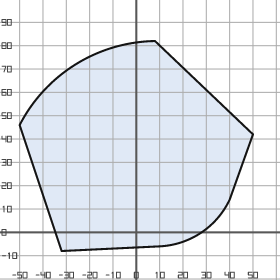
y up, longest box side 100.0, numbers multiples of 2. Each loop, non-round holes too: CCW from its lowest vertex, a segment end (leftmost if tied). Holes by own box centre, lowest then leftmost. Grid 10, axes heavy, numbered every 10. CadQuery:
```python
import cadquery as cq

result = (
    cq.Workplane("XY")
    .moveTo(-32.0, -8.0)
    .lineTo(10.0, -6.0)
    .threePointArc((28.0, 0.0), (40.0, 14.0))
    .lineTo(50.0, 42.0)
    .lineTo(8.0, 82.0)
    .threePointArc((-26.0, 72.0), (-50.0, 46.0))
    .close()
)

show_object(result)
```